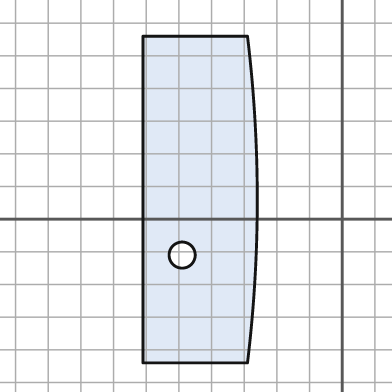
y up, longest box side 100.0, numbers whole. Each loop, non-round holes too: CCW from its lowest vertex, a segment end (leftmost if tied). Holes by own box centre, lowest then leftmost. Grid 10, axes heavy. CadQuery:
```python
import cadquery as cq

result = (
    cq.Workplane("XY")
    .moveTo(-61.0, -44.0)
    .lineTo(-29.0, -44.0)
    .threePointArc((-26.0, 6.0), (-29.0, 56.0))
    .lineTo(-61.0, 56.0)
    .close()
    .moveTo(-49.0, -11.0)
    .circle(4.0)
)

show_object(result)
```